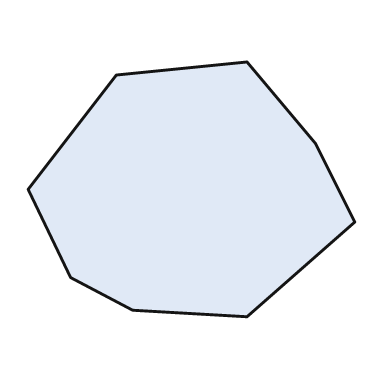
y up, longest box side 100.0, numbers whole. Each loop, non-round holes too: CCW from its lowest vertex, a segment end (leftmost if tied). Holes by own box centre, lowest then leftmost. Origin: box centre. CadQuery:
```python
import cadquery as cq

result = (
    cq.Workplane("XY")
    .moveTo(17.0, -39.0)
    .lineTo(50.0, -10.0)
    .lineTo(38.0, 14.0)
    .lineTo(17.0, 39.0)
    .lineTo(-23.0, 35.0)
    .lineTo(-50.0, 0.0)
    .lineTo(-37.0, -27.0)
    .lineTo(-18.0, -37.0)
    .close()
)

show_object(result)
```